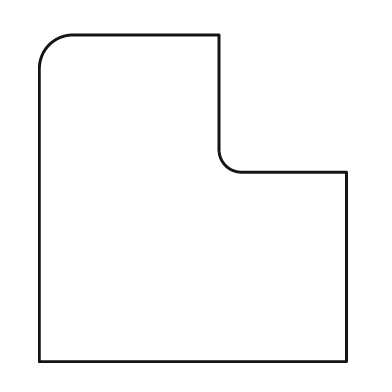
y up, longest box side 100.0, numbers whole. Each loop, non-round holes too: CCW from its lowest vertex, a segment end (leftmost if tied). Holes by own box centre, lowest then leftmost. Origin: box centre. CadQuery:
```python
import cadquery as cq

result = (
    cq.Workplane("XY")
    .moveTo(-47.0, -50.0)
    .lineTo(47.0, -50.0)
    .lineTo(47.0, 8.0)
    .lineTo(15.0, 8.0)
    .threePointArc((10.0, 10.0), (8.0, 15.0))
    .lineTo(8.0, 50.0)
    .lineTo(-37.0, 50.0)
    .threePointArc((-44.0, 47.0), (-47.0, 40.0))
    .close()
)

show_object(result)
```